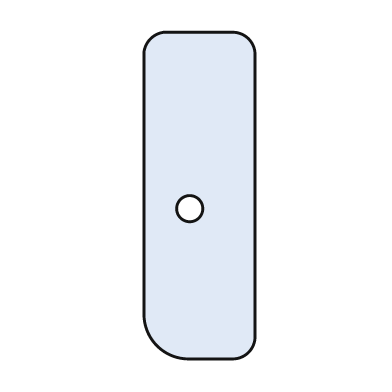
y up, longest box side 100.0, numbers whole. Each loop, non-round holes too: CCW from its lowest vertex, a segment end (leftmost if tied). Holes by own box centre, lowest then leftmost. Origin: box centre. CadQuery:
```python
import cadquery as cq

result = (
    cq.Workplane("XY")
    .moveTo(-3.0, -50.0)
    .lineTo(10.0, -50.0)
    .threePointArc((15.0, -48.0), (17.0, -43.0))
    .lineTo(17.0, 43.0)
    .threePointArc((15.0, 48.0), (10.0, 50.0))
    .lineTo(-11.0, 50.0)
    .threePointArc((-15.0, 48.0), (-17.0, 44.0))
    .lineTo(-17.0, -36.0)
    .threePointArc((-13.0, -46.0), (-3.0, -50.0))
    .close()
    .moveTo(-3.0, -4.0)
    .circle(4.0)
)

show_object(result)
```